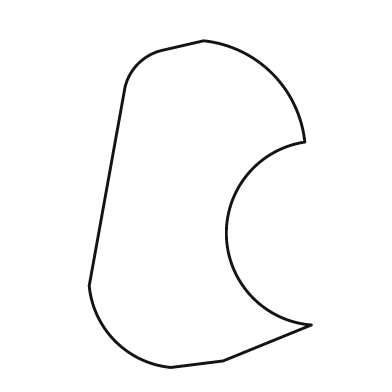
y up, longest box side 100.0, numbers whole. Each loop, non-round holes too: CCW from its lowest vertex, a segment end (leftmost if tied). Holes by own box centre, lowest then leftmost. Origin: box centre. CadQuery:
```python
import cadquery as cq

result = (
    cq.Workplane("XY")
    .moveTo(-9.0, -50.0)
    .lineTo(7.0, -48.0)
    .lineTo(34.0, -37.0)
    .threePointArc((8.0, -10.0), (32.0, 19.0))
    .threePointArc((22.0, 40.0), (1.0, 50.0))
    .lineTo(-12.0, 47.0)
    .threePointArc((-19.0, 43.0), (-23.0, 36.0))
    .lineTo(-34.0, -25.0)
    .threePointArc((-26.0, -42.0), (-9.0, -50.0))
    .close()
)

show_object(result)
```